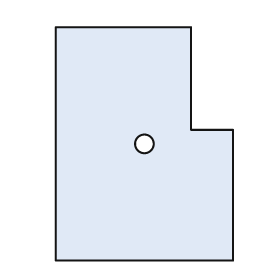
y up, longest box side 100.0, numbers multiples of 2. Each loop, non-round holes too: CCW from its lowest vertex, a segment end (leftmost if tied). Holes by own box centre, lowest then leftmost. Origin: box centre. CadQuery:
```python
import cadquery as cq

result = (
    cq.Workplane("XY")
    .moveTo(-38.0, -50.0)
    .lineTo(38.0, -50.0)
    .lineTo(38.0, 6.0)
    .lineTo(20.0, 6.0)
    .lineTo(20.0, 50.0)
    .lineTo(-38.0, 50.0)
    .close()
    .moveTo(0.0, 0.0)
    .circle(4.0)
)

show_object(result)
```